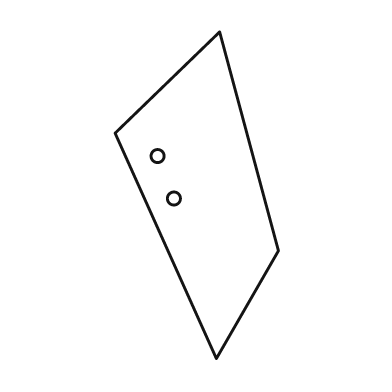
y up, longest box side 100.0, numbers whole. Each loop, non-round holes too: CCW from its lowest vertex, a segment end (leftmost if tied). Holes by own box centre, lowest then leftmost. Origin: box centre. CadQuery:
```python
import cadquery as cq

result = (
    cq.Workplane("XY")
    .moveTo(6.0, -50.0)
    .lineTo(25.0, -17.0)
    .lineTo(7.0, 50.0)
    .lineTo(-25.0, 19.0)
    .close()
    .moveTo(-7.0, -1.0)
    .circle(2.0)
    .moveTo(-12.0, 12.0)
    .circle(2.0)
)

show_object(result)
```